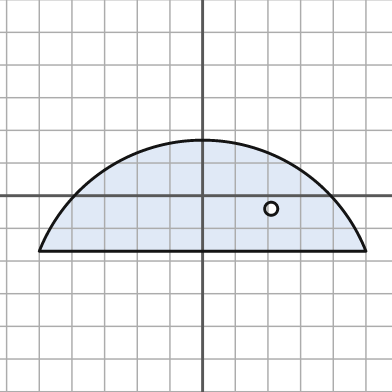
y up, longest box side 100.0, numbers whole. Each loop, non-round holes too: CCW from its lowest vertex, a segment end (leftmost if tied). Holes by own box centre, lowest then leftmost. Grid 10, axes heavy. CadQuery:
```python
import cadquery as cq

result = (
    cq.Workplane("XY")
    .moveTo(-50.0, -17.0)
    .lineTo(50.0, -17.0)
    .threePointArc((0.0, 17.0), (-50.0, -17.0))
    .close()
    .moveTo(21.0, -4.0)
    .circle(2.0)
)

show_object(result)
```